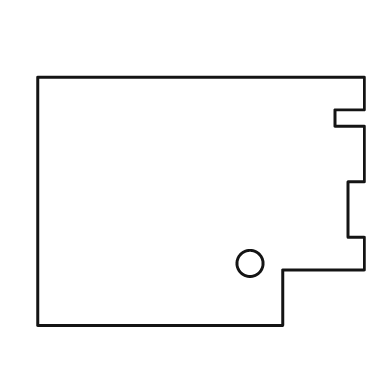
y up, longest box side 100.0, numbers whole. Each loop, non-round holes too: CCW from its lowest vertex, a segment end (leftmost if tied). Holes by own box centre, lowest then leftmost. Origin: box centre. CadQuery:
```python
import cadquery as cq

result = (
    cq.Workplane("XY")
    .moveTo(-50.0, -38.0)
    .lineTo(25.0, -38.0)
    .lineTo(25.0, -21.0)
    .lineTo(50.0, -21.0)
    .lineTo(50.0, -11.0)
    .lineTo(45.0, -11.0)
    .lineTo(45.0, 6.0)
    .lineTo(50.0, 6.0)
    .lineTo(50.0, 23.0)
    .lineTo(41.0, 23.0)
    .lineTo(41.0, 28.0)
    .lineTo(50.0, 28.0)
    .lineTo(50.0, 38.0)
    .lineTo(-50.0, 38.0)
    .close()
    .moveTo(15.0, -19.0)
    .circle(4.0)
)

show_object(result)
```